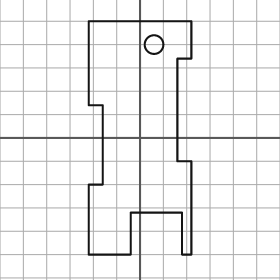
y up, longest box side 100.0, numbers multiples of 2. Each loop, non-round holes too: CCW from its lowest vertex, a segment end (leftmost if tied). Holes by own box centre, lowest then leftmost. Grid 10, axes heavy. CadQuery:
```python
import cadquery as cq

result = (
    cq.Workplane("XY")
    .moveTo(-22.0, -50.0)
    .lineTo(-4.0, -50.0)
    .lineTo(-4.0, -32.0)
    .lineTo(18.0, -32.0)
    .lineTo(18.0, -50.0)
    .lineTo(22.0, -50.0)
    .lineTo(22.0, -10.0)
    .lineTo(16.0, -10.0)
    .lineTo(16.0, 34.0)
    .lineTo(22.0, 34.0)
    .lineTo(22.0, 50.0)
    .lineTo(-22.0, 50.0)
    .lineTo(-22.0, 14.0)
    .lineTo(-16.0, 14.0)
    .lineTo(-16.0, -20.0)
    .lineTo(-22.0, -20.0)
    .close()
    .moveTo(6.0, 40.0)
    .circle(4.0)
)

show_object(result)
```